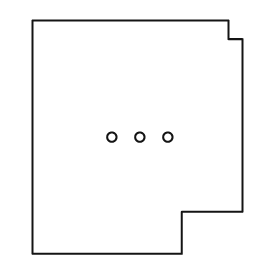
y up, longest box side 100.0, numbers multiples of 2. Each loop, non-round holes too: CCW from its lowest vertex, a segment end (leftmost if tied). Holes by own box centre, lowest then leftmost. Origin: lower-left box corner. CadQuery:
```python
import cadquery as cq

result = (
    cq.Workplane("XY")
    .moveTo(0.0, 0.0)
    .lineTo(64.0, 0.0)
    .lineTo(64.0, 18.0)
    .lineTo(90.0, 18.0)
    .lineTo(90.0, 92.0)
    .lineTo(84.0, 92.0)
    .lineTo(84.0, 100.0)
    .lineTo(0.0, 100.0)
    .close()
    .moveTo(34.0, 50.0)
    .circle(2.0)
    .moveTo(46.0, 50.0)
    .circle(2.0)
    .moveTo(58.0, 50.0)
    .circle(2.0)
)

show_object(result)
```